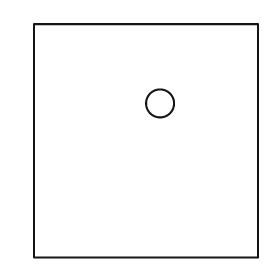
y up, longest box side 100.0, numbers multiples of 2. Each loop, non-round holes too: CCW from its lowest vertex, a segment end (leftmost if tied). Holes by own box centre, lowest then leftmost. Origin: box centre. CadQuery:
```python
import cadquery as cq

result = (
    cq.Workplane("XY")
    .moveTo(-48.0, -50.0)
    .lineTo(48.0, -50.0)
    .lineTo(48.0, 50.0)
    .lineTo(-48.0, 50.0)
    .close()
    .moveTo(6.0, 16.0)
    .circle(6.0)
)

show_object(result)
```